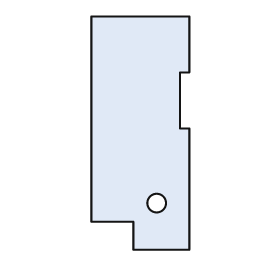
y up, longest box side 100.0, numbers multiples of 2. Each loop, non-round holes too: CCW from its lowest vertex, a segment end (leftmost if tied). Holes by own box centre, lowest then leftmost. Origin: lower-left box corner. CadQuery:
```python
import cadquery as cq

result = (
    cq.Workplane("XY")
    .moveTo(18.0, 0.0)
    .lineTo(42.0, 0.0)
    .lineTo(42.0, 52.0)
    .lineTo(38.0, 52.0)
    .lineTo(38.0, 76.0)
    .lineTo(42.0, 76.0)
    .lineTo(42.0, 100.0)
    .lineTo(0.0, 100.0)
    .lineTo(0.0, 12.0)
    .lineTo(18.0, 12.0)
    .close()
    .moveTo(28.0, 20.0)
    .circle(4.0)
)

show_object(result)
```